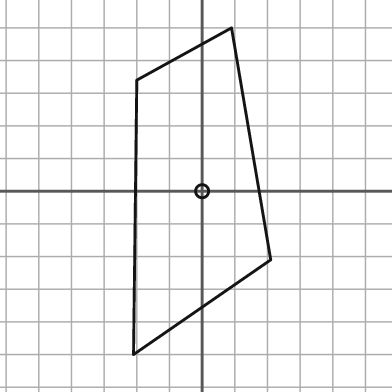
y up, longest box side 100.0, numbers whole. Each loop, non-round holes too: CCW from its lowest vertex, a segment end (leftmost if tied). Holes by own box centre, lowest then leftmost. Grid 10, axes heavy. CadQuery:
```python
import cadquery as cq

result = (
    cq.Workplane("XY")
    .moveTo(-21.0, -50.0)
    .lineTo(21.0, -21.0)
    .lineTo(9.0, 50.0)
    .lineTo(-20.0, 34.0)
    .close()
    .moveTo(0.0, 0.0)
    .circle(2.0)
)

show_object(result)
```